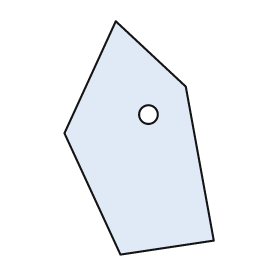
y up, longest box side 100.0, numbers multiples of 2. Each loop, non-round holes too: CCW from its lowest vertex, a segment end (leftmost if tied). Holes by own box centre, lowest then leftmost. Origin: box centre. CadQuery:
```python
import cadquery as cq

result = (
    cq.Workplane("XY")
    .moveTo(-8.0, -50.0)
    .lineTo(32.0, -44.0)
    .lineTo(20.0, 22.0)
    .lineTo(-10.0, 50.0)
    .lineTo(-32.0, 2.0)
    .close()
    .moveTo(4.0, 10.0)
    .circle(4.0)
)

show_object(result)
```